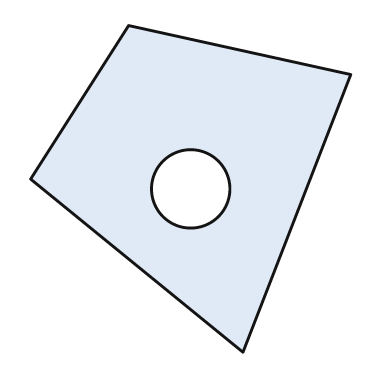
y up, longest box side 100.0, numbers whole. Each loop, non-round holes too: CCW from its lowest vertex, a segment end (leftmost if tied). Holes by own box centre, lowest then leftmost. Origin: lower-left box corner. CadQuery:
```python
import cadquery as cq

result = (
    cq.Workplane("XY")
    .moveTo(65.0, 0.0)
    .lineTo(98.0, 85.0)
    .lineTo(30.0, 100.0)
    .lineTo(0.0, 53.0)
    .close()
    .moveTo(49.0, 50.0)
    .circle(12.0)
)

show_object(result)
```